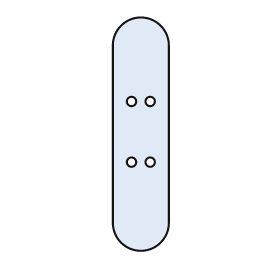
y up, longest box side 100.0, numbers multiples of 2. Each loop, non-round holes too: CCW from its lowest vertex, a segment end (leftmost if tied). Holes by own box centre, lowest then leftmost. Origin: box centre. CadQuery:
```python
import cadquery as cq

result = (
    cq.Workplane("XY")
    .moveTo(-12.0, -38.0)
    .threePointArc((0.0, -50.0), (12.0, -38.0))
    .lineTo(12.0, 38.0)
    .threePointArc((0.0, 50.0), (-12.0, 38.0))
    .close()
    .moveTo(-4.0, -12.0)
    .circle(2.0)
    .moveTo(4.0, -12.0)
    .circle(2.0)
    .moveTo(-4.0, 14.0)
    .circle(2.0)
    .moveTo(4.0, 14.0)
    .circle(2.0)
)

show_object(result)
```